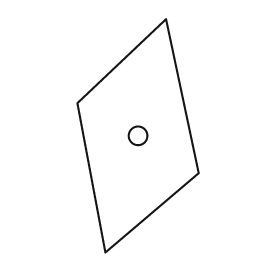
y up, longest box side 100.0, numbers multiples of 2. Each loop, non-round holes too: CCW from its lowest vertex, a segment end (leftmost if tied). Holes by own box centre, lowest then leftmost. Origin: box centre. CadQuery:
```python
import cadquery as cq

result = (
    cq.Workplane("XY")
    .moveTo(-14.0, -50.0)
    .lineTo(26.0, -16.0)
    .lineTo(12.0, 50.0)
    .lineTo(-26.0, 14.0)
    .close()
    .moveTo(0.0, 0.0)
    .circle(4.0)
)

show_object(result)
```